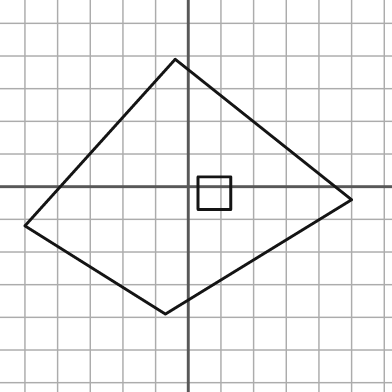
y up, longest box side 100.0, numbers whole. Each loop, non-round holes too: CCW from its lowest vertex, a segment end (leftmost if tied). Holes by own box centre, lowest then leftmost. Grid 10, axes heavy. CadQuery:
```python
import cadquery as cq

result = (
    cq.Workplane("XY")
    .moveTo(-7.0, -39.0)
    .lineTo(50.0, -4.0)
    .lineTo(-4.0, 39.0)
    .lineTo(-50.0, -12.0)
    .close()
    .moveTo(3.0, -7.0)
    .lineTo(13.0, -7.0)
    .lineTo(13.0, 3.0)
    .lineTo(3.0, 3.0)
    .close()
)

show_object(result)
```